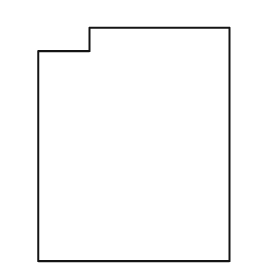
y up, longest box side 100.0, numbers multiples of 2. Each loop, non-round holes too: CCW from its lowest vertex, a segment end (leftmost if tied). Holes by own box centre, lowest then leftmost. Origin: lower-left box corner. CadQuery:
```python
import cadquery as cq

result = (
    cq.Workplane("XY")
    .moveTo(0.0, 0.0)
    .lineTo(82.0, 0.0)
    .lineTo(82.0, 100.0)
    .lineTo(22.0, 100.0)
    .lineTo(22.0, 90.0)
    .lineTo(0.0, 90.0)
    .close()
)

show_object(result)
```